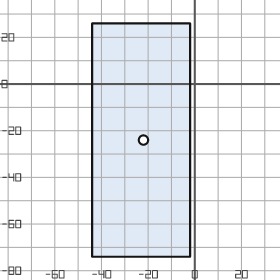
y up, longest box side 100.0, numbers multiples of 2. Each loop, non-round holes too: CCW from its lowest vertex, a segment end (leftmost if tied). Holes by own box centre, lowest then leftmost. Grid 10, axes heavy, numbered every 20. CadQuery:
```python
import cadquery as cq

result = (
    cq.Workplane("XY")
    .moveTo(-44.0, -74.0)
    .lineTo(-2.0, -74.0)
    .lineTo(-2.0, 26.0)
    .lineTo(-44.0, 26.0)
    .close()
    .moveTo(-22.0, -24.0)
    .circle(2.0)
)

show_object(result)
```